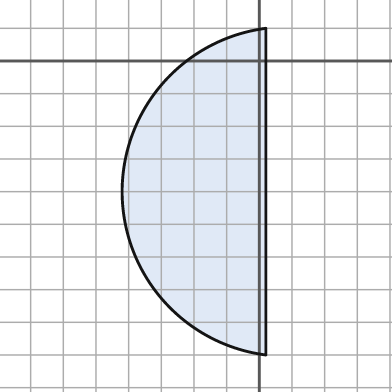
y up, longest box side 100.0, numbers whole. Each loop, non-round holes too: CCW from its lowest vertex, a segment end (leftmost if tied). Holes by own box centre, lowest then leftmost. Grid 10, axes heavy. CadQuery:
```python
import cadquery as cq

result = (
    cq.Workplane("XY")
    .moveTo(2.0, -90.0)
    .lineTo(2.0, 10.0)
    .threePointArc((-42.0, -40.0), (2.0, -90.0))
    .close()
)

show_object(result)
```